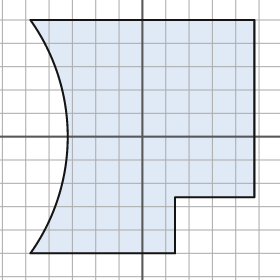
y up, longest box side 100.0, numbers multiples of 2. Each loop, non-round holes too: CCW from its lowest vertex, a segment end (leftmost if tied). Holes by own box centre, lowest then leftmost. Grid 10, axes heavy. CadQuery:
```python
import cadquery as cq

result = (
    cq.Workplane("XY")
    .moveTo(-48.0, -50.0)
    .lineTo(14.0, -50.0)
    .lineTo(14.0, -26.0)
    .lineTo(48.0, -26.0)
    .lineTo(48.0, 50.0)
    .lineTo(-48.0, 50.0)
    .threePointArc((-32.0, 0.0), (-48.0, -50.0))
    .close()
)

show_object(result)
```